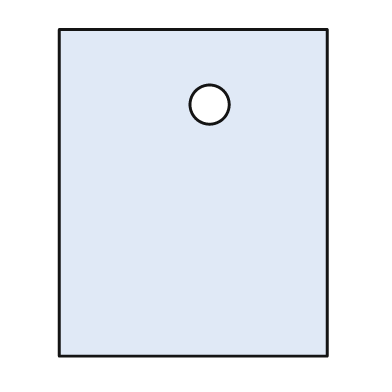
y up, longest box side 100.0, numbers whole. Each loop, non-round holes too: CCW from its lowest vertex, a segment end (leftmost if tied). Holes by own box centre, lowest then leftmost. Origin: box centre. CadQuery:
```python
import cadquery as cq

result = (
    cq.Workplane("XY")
    .moveTo(-41.0, -50.0)
    .lineTo(41.0, -50.0)
    .lineTo(41.0, 50.0)
    .lineTo(-41.0, 50.0)
    .close()
    .moveTo(5.0, 27.0)
    .circle(6.0)
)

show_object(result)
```